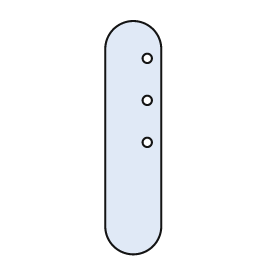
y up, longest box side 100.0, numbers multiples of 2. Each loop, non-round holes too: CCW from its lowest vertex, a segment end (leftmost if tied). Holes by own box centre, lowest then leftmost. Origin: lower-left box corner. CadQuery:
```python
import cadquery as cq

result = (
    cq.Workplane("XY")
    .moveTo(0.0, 12.0)
    .threePointArc((12.0, 0.0), (24.0, 12.0))
    .lineTo(24.0, 88.0)
    .threePointArc((12.0, 100.0), (0.0, 88.0))
    .close()
    .moveTo(18.0, 48.0)
    .circle(2.0)
    .moveTo(18.0, 66.0)
    .circle(2.0)
    .moveTo(18.0, 84.0)
    .circle(2.0)
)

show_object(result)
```